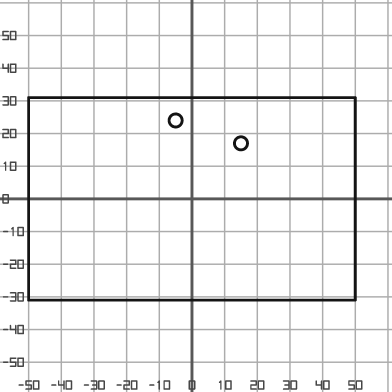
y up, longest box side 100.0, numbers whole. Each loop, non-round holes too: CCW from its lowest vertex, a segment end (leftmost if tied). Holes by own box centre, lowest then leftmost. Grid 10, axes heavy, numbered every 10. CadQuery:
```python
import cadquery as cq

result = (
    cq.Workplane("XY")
    .moveTo(-50.0, -31.0)
    .lineTo(50.0, -31.0)
    .lineTo(50.0, 31.0)
    .lineTo(-50.0, 31.0)
    .close()
    .moveTo(15.0, 17.0)
    .circle(2.0)
    .moveTo(-5.0, 24.0)
    .circle(2.0)
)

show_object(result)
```